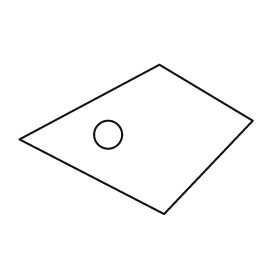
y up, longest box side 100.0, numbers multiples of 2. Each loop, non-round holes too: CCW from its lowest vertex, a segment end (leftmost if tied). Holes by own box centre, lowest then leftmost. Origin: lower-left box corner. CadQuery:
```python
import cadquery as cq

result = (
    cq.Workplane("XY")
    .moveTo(62.0, 0.0)
    .lineTo(100.0, 40.0)
    .lineTo(60.0, 64.0)
    .lineTo(0.0, 32.0)
    .close()
    .moveTo(38.0, 34.0)
    .circle(6.0)
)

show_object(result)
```